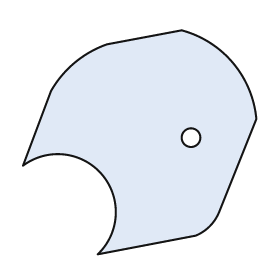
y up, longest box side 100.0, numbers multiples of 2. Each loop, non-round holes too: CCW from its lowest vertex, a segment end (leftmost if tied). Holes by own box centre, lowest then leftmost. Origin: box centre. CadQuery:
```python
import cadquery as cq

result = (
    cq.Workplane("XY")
    .moveTo(-18.0, -48.0)
    .lineTo(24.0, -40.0)
    .threePointArc((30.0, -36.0), (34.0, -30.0))
    .lineTo(50.0, 10.0)
    .threePointArc((40.0, 34.0), (18.0, 48.0))
    .lineTo(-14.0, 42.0)
    .threePointArc((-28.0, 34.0), (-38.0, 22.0))
    .lineTo(-50.0, -10.0)
    .threePointArc((-16.0, -14.0), (-18.0, -48.0))
    .close()
    .moveTo(22.0, 2.0)
    .circle(4.0)
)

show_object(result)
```